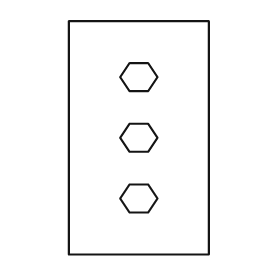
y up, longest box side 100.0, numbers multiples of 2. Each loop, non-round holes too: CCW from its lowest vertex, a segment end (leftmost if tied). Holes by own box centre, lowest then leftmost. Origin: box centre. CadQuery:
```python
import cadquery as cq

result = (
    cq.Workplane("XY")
    .moveTo(-30.0, -50.0)
    .lineTo(30.0, -50.0)
    .lineTo(30.0, 50.0)
    .lineTo(-30.0, 50.0)
    .close()
    .moveTo(-4.0, -32.0)
    .lineTo(4.0, -32.0)
    .lineTo(8.0, -26.0)
    .lineTo(4.0, -20.0)
    .lineTo(-4.0, -20.0)
    .lineTo(-8.0, -26.0)
    .close()
    .moveTo(-4.0, -6.0)
    .lineTo(4.0, -6.0)
    .lineTo(8.0, 0.0)
    .lineTo(4.0, 6.0)
    .lineTo(-4.0, 6.0)
    .lineTo(-8.0, 0.0)
    .close()
    .moveTo(-4.0, 20.0)
    .lineTo(4.0, 20.0)
    .lineTo(8.0, 26.0)
    .lineTo(4.0, 32.0)
    .lineTo(-4.0, 32.0)
    .lineTo(-8.0, 26.0)
    .close()
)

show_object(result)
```